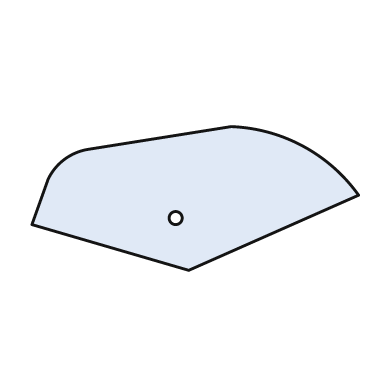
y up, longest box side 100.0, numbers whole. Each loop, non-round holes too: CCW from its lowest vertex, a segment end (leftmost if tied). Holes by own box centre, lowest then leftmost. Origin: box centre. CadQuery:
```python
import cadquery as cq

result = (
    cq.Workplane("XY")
    .moveTo(-2.0, -22.0)
    .lineTo(50.0, 1.0)
    .threePointArc((33.0, 16.0), (11.0, 22.0))
    .lineTo(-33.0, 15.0)
    .threePointArc((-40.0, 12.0), (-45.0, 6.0))
    .lineTo(-50.0, -8.0)
    .close()
    .moveTo(-6.0, -6.0)
    .circle(2.0)
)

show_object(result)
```